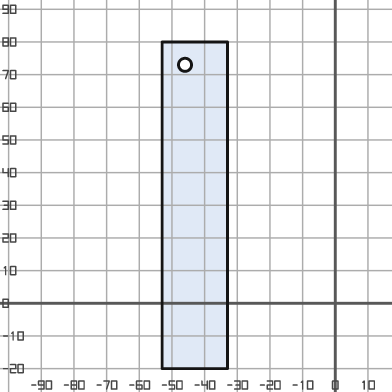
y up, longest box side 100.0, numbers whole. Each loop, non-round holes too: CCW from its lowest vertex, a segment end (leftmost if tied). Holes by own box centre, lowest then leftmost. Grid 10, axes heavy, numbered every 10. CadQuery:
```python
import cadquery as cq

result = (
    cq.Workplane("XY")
    .moveTo(-53.0, -20.0)
    .lineTo(-33.0, -20.0)
    .lineTo(-33.0, 80.0)
    .lineTo(-53.0, 80.0)
    .close()
    .moveTo(-46.0, 73.0)
    .circle(2.0)
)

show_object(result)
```